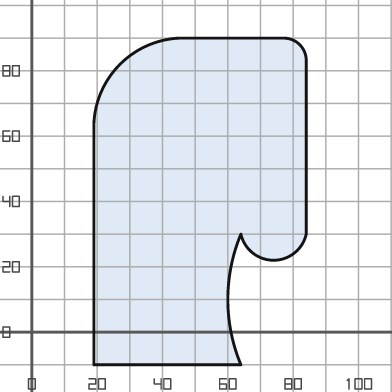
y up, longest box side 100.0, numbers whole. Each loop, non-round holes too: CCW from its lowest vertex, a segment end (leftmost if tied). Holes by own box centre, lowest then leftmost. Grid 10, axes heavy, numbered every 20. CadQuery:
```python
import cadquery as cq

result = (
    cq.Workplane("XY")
    .moveTo(19.0, -10.0)
    .lineTo(64.0, -10.0)
    .threePointArc((60.0, 10.0), (64.0, 30.0))
    .threePointArc((74.0, 22.0), (84.0, 30.0))
    .lineTo(84.0, 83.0)
    .threePointArc((82.0, 88.0), (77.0, 90.0))
    .lineTo(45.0, 90.0)
    .threePointArc((27.0, 82.0), (19.0, 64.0))
    .close()
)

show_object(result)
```